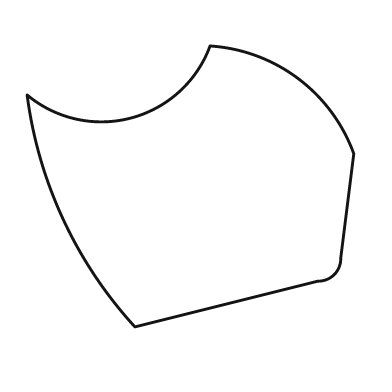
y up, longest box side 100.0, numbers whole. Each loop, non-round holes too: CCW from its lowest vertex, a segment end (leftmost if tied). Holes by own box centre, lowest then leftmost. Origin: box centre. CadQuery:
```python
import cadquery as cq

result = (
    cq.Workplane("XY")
    .moveTo(-17.0, -43.0)
    .lineTo(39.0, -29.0)
    .threePointArc((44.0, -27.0), (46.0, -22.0))
    .lineTo(50.0, 10.0)
    .threePointArc((33.0, 33.0), (6.0, 43.0))
    .threePointArc((-18.0, 21.0), (-50.0, 28.0))
    .threePointArc((-39.0, -10.0), (-17.0, -43.0))
    .close()
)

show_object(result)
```